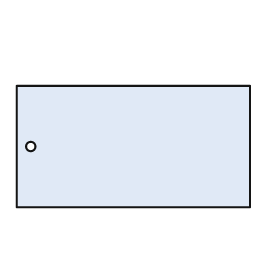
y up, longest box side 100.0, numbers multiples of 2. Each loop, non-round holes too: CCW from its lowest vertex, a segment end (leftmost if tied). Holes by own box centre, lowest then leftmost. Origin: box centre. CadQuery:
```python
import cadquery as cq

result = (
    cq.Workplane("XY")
    .moveTo(-50.0, -26.0)
    .lineTo(50.0, -26.0)
    .lineTo(50.0, 26.0)
    .lineTo(-50.0, 26.0)
    .close()
    .moveTo(-44.0, 0.0)
    .circle(2.0)
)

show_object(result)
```